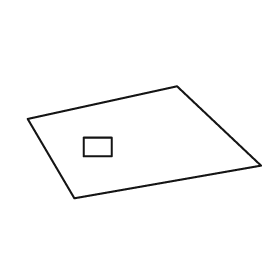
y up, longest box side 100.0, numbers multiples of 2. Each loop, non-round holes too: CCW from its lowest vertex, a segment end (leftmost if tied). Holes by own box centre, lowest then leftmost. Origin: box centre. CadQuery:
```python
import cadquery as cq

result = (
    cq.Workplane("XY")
    .moveTo(-30.0, -24.0)
    .lineTo(50.0, -10.0)
    .lineTo(14.0, 24.0)
    .lineTo(-50.0, 10.0)
    .close()
    .moveTo(-26.0, -6.0)
    .lineTo(-14.0, -6.0)
    .lineTo(-14.0, 2.0)
    .lineTo(-26.0, 2.0)
    .close()
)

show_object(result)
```